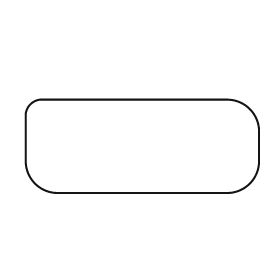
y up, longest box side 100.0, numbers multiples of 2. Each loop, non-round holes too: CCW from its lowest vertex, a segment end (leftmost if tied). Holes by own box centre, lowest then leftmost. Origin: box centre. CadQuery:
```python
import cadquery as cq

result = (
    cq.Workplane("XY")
    .moveTo(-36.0, -20.0)
    .lineTo(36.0, -20.0)
    .threePointArc((46.0, -16.0), (50.0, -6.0))
    .lineTo(50.0, 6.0)
    .threePointArc((46.0, 16.0), (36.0, 20.0))
    .lineTo(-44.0, 20.0)
    .threePointArc((-48.0, 18.0), (-50.0, 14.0))
    .lineTo(-50.0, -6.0)
    .threePointArc((-46.0, -16.0), (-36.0, -20.0))
    .close()
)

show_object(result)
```